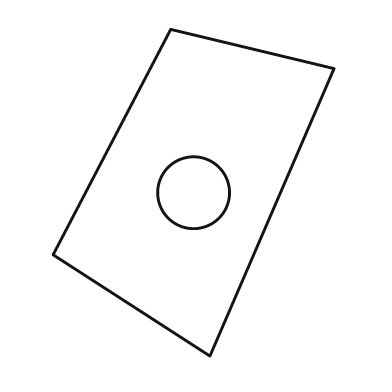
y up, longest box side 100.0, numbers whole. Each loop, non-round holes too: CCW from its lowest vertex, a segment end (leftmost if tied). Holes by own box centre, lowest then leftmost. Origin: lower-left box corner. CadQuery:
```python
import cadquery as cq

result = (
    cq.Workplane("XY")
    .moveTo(48.0, 0.0)
    .lineTo(86.0, 88.0)
    .lineTo(36.0, 100.0)
    .lineTo(0.0, 31.0)
    .close()
    .moveTo(43.0, 50.0)
    .circle(11.0)
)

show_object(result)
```